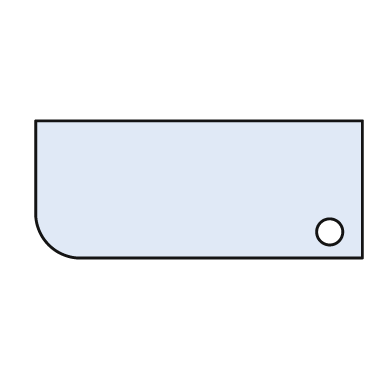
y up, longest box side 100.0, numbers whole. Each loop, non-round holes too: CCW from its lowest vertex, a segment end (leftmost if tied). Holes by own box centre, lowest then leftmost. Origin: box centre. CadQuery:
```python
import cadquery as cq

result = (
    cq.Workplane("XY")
    .moveTo(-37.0, -21.0)
    .lineTo(50.0, -21.0)
    .lineTo(50.0, 21.0)
    .lineTo(-50.0, 21.0)
    .lineTo(-50.0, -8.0)
    .threePointArc((-46.0, -17.0), (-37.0, -21.0))
    .close()
    .moveTo(40.0, -13.0)
    .circle(4.0)
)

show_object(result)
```